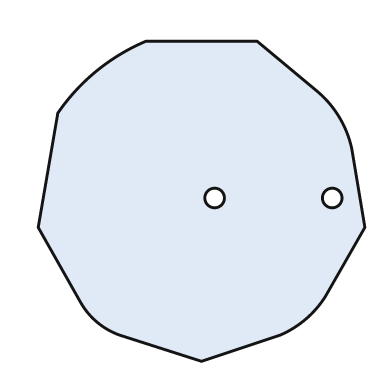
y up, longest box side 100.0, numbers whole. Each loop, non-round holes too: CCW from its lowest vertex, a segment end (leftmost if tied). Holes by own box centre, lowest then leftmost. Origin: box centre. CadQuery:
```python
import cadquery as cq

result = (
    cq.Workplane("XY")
    .moveTo(0.0, -49.0)
    .lineTo(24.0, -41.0)
    .threePointArc((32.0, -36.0), (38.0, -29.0))
    .lineTo(50.0, -8.0)
    .lineTo(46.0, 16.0)
    .threePointArc((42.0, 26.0), (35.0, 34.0))
    .lineTo(17.0, 49.0)
    .lineTo(-17.0, 49.0)
    .threePointArc((-32.0, 40.0), (-44.0, 27.0))
    .lineTo(-50.0, -8.0)
    .lineTo(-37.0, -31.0)
    .threePointArc((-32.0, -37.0), (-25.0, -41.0))
    .close()
    .moveTo(4.0, 1.0)
    .circle(3.0)
    .moveTo(40.0, 1.0)
    .circle(3.0)
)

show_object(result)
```